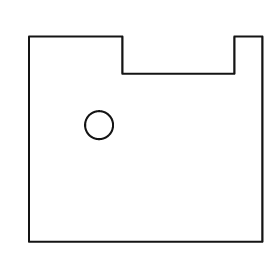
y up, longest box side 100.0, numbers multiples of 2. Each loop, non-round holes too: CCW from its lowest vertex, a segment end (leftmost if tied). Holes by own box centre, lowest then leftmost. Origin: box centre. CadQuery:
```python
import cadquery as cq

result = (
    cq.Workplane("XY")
    .moveTo(-50.0, -44.0)
    .lineTo(50.0, -44.0)
    .lineTo(50.0, 44.0)
    .lineTo(38.0, 44.0)
    .lineTo(38.0, 28.0)
    .lineTo(-10.0, 28.0)
    .lineTo(-10.0, 44.0)
    .lineTo(-50.0, 44.0)
    .close()
    .moveTo(-20.0, 6.0)
    .circle(6.0)
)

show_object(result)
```